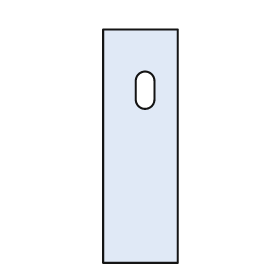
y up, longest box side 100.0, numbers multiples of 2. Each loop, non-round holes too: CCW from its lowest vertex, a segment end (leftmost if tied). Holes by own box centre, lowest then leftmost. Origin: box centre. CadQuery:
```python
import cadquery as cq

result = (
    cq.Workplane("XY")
    .moveTo(-16.0, -50.0)
    .lineTo(16.0, -50.0)
    .lineTo(16.0, 50.0)
    .lineTo(-16.0, 50.0)
    .close()
    .moveTo(-2.0, 20.0)
    .threePointArc((2.0, 16.0), (6.0, 20.0))
    .lineTo(6.0, 28.0)
    .threePointArc((2.0, 32.0), (-2.0, 28.0))
    .close()
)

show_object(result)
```